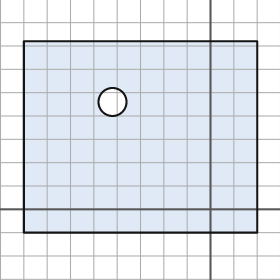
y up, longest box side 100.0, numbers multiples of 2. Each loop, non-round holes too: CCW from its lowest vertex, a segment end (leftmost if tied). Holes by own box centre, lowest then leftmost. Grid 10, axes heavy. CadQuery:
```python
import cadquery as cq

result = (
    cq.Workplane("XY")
    .moveTo(-80.0, -10.0)
    .lineTo(20.0, -10.0)
    .lineTo(20.0, 72.0)
    .lineTo(-80.0, 72.0)
    .close()
    .moveTo(-42.0, 46.0)
    .circle(6.0)
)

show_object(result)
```